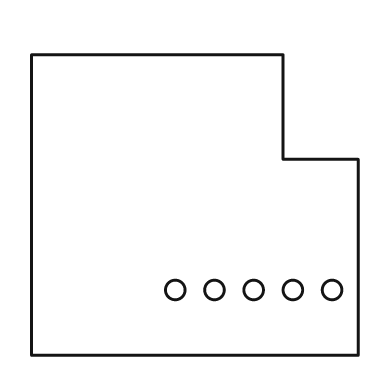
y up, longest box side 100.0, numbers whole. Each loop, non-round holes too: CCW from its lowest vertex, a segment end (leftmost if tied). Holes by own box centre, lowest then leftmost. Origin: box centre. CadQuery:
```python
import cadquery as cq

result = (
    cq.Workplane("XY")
    .moveTo(-50.0, -46.0)
    .lineTo(50.0, -46.0)
    .lineTo(50.0, 14.0)
    .lineTo(27.0, 14.0)
    .lineTo(27.0, 46.0)
    .lineTo(-50.0, 46.0)
    .close()
    .moveTo(-6.0, -26.0)
    .circle(3.0)
    .moveTo(6.0, -26.0)
    .circle(3.0)
    .moveTo(18.0, -26.0)
    .circle(3.0)
    .moveTo(30.0, -26.0)
    .circle(3.0)
    .moveTo(42.0, -26.0)
    .circle(3.0)
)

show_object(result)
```